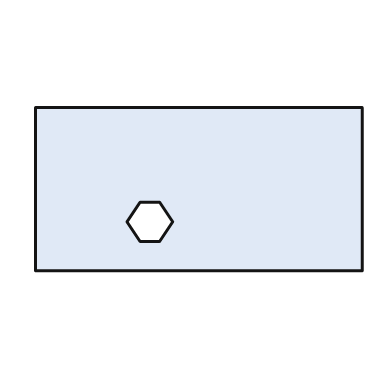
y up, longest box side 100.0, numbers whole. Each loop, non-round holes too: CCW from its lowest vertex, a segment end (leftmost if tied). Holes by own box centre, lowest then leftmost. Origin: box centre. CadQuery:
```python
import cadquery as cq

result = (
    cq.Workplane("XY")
    .moveTo(-50.0, -25.0)
    .lineTo(50.0, -25.0)
    .lineTo(50.0, 25.0)
    .lineTo(-50.0, 25.0)
    .close()
    .moveTo(-18.0, -16.0)
    .lineTo(-12.0, -16.0)
    .lineTo(-8.0, -10.0)
    .lineTo(-12.0, -4.0)
    .lineTo(-18.0, -4.0)
    .lineTo(-22.0, -10.0)
    .close()
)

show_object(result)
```